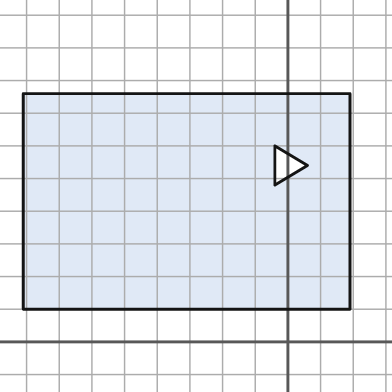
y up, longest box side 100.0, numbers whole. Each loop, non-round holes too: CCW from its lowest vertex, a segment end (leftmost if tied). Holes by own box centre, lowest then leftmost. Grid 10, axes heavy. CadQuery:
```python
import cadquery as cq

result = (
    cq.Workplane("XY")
    .moveTo(-81.0, 10.0)
    .lineTo(19.0, 10.0)
    .lineTo(19.0, 76.0)
    .lineTo(-81.0, 76.0)
    .close()
    .moveTo(-4.0, 48.0)
    .lineTo(6.0, 54.0)
    .lineTo(-4.0, 60.0)
    .close()
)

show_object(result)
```